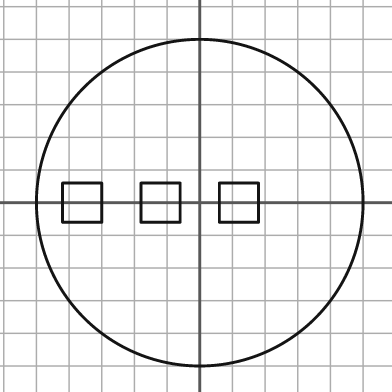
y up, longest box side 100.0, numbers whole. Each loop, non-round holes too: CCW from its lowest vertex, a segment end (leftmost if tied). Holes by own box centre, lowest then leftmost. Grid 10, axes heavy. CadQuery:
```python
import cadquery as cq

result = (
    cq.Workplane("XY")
    .moveTo(0.0, 0.0)
    .circle(50.0)
    .moveTo(-42.0, -6.0)
    .lineTo(-30.0, -6.0)
    .lineTo(-30.0, 6.0)
    .lineTo(-42.0, 6.0)
    .close()
    .moveTo(-18.0, -6.0)
    .lineTo(-6.0, -6.0)
    .lineTo(-6.0, 6.0)
    .lineTo(-18.0, 6.0)
    .close()
    .moveTo(6.0, -6.0)
    .lineTo(18.0, -6.0)
    .lineTo(18.0, 6.0)
    .lineTo(6.0, 6.0)
    .close()
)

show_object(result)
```